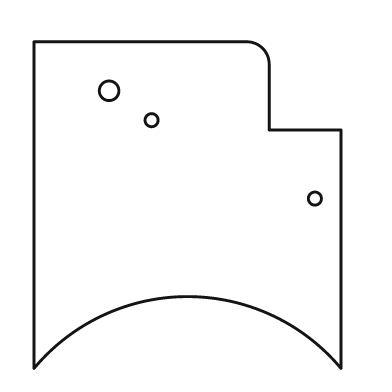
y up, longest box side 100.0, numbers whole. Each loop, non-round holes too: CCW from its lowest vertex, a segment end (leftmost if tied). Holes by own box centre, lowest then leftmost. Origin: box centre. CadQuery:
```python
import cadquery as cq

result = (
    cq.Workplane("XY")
    .moveTo(-47.0, -50.0)
    .threePointArc((0.0, -28.0), (47.0, -50.0))
    .lineTo(47.0, 23.0)
    .lineTo(25.0, 23.0)
    .lineTo(25.0, 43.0)
    .threePointArc((23.0, 48.0), (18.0, 50.0))
    .lineTo(-47.0, 50.0)
    .close()
    .moveTo(39.0, 2.0)
    .circle(2.0)
    .moveTo(-11.0, 26.0)
    .circle(2.0)
    .moveTo(-24.0, 35.0)
    .circle(3.0)
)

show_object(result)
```